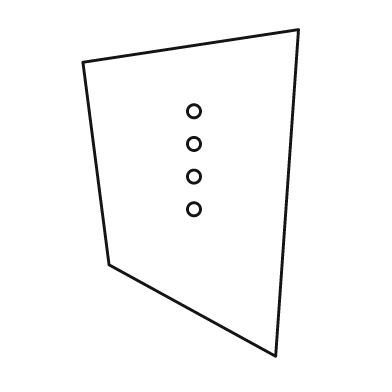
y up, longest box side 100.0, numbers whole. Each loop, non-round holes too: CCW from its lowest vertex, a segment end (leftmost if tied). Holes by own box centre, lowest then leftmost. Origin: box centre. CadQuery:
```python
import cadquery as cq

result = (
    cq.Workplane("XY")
    .moveTo(26.0, -50.0)
    .lineTo(33.0, 50.0)
    .lineTo(-33.0, 40.0)
    .lineTo(-25.0, -22.0)
    .close()
    .moveTo(1.0, -5.0)
    .circle(2.0)
    .moveTo(1.0, 5.0)
    .circle(2.0)
    .moveTo(1.0, 15.0)
    .circle(2.0)
    .moveTo(1.0, 25.0)
    .circle(2.0)
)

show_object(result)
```